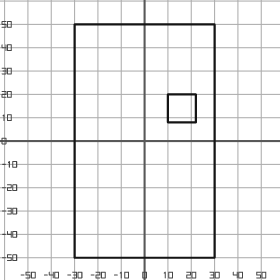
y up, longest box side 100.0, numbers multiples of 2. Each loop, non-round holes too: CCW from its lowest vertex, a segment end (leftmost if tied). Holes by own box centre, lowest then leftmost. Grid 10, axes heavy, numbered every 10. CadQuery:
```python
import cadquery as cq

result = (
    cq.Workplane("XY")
    .moveTo(-30.0, -50.0)
    .lineTo(30.0, -50.0)
    .lineTo(30.0, 50.0)
    .lineTo(-30.0, 50.0)
    .close()
    .moveTo(10.0, 8.0)
    .lineTo(22.0, 8.0)
    .lineTo(22.0, 20.0)
    .lineTo(10.0, 20.0)
    .close()
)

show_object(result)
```